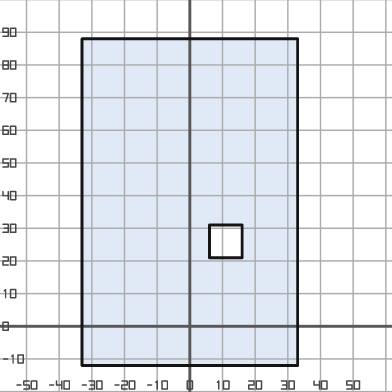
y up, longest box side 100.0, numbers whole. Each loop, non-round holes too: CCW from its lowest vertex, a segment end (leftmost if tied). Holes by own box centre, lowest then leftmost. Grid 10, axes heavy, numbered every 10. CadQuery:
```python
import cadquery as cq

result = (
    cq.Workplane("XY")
    .moveTo(-33.0, -12.0)
    .lineTo(33.0, -12.0)
    .lineTo(33.0, 88.0)
    .lineTo(-33.0, 88.0)
    .close()
    .moveTo(6.0, 21.0)
    .lineTo(16.0, 21.0)
    .lineTo(16.0, 31.0)
    .lineTo(6.0, 31.0)
    .close()
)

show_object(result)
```